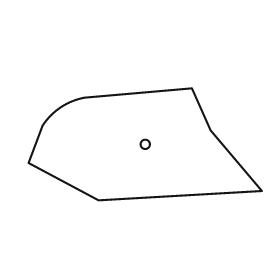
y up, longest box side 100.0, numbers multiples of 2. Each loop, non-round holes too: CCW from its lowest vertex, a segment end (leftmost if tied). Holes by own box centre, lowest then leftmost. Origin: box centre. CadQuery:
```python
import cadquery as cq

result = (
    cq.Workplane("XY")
    .moveTo(-20.0, -24.0)
    .lineTo(50.0, -20.0)
    .lineTo(28.0, 6.0)
    .lineTo(20.0, 24.0)
    .lineTo(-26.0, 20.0)
    .threePointArc((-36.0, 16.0), (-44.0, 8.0))
    .lineTo(-50.0, -8.0)
    .close()
    .moveTo(0.0, 0.0)
    .circle(2.0)
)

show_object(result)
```